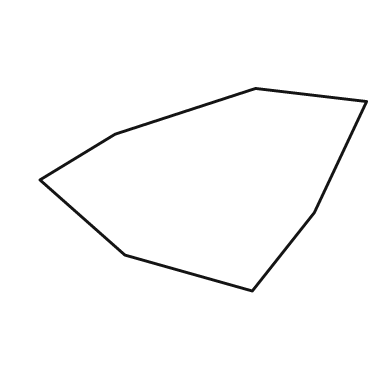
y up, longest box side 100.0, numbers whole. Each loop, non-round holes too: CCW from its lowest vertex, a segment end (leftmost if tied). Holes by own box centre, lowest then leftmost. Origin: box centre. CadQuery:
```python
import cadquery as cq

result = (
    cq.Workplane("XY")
    .moveTo(15.0, -31.0)
    .lineTo(34.0, -7.0)
    .lineTo(50.0, 27.0)
    .lineTo(16.0, 31.0)
    .lineTo(-27.0, 17.0)
    .lineTo(-50.0, 3.0)
    .lineTo(-24.0, -20.0)
    .close()
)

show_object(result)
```